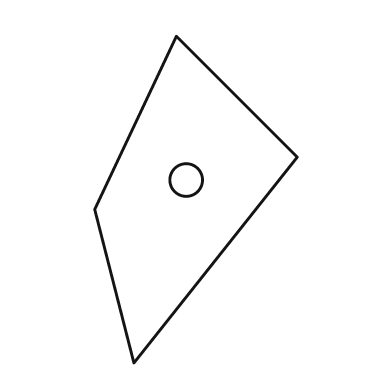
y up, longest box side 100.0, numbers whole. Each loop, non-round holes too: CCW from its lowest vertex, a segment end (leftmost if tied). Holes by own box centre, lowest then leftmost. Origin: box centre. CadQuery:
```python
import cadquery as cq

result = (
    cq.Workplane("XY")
    .moveTo(-19.0, -50.0)
    .lineTo(31.0, 13.0)
    .lineTo(-6.0, 50.0)
    .lineTo(-31.0, -3.0)
    .close()
    .moveTo(-3.0, 6.0)
    .circle(5.0)
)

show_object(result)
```